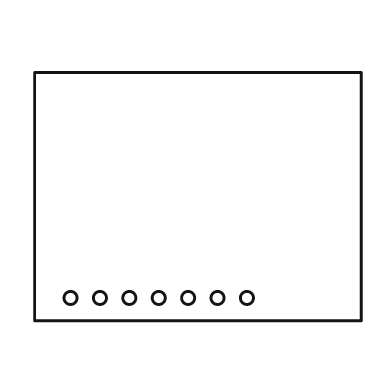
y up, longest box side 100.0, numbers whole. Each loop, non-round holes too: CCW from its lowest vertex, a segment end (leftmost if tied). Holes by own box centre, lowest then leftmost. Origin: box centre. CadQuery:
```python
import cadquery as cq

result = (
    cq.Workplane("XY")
    .moveTo(-50.0, -38.0)
    .lineTo(50.0, -38.0)
    .lineTo(50.0, 38.0)
    .lineTo(-50.0, 38.0)
    .close()
    .moveTo(-39.0, -31.0)
    .circle(2.0)
    .moveTo(-30.0, -31.0)
    .circle(2.0)
    .moveTo(-21.0, -31.0)
    .circle(2.0)
    .moveTo(-12.0, -31.0)
    .circle(2.0)
    .moveTo(-3.0, -31.0)
    .circle(2.0)
    .moveTo(6.0, -31.0)
    .circle(2.0)
    .moveTo(15.0, -31.0)
    .circle(2.0)
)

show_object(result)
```